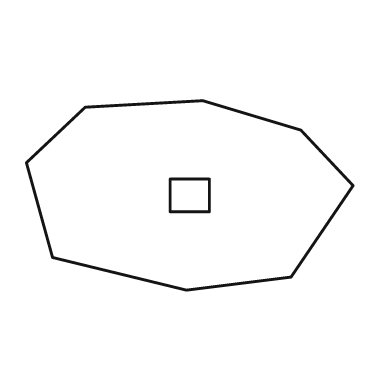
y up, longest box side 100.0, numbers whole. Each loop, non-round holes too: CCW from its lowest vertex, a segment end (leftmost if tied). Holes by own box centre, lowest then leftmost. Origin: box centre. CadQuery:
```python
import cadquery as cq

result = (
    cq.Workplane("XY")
    .moveTo(-1.0, -29.0)
    .lineTo(31.0, -25.0)
    .lineTo(50.0, 3.0)
    .lineTo(34.0, 20.0)
    .lineTo(4.0, 29.0)
    .lineTo(-32.0, 27.0)
    .lineTo(-50.0, 10.0)
    .lineTo(-42.0, -19.0)
    .close()
    .moveTo(-6.0, -5.0)
    .lineTo(6.0, -5.0)
    .lineTo(6.0, 5.0)
    .lineTo(-6.0, 5.0)
    .close()
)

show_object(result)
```